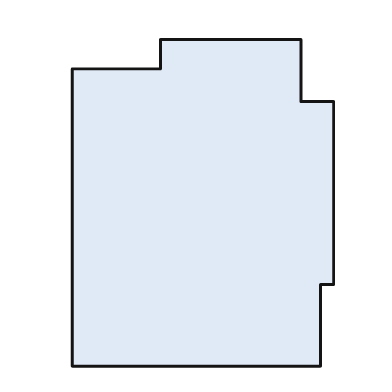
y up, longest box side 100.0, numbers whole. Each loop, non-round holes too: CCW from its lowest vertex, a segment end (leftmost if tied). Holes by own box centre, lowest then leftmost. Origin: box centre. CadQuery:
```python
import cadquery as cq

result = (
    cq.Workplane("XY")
    .moveTo(-40.0, -50.0)
    .lineTo(36.0, -50.0)
    .lineTo(36.0, -25.0)
    .lineTo(40.0, -25.0)
    .lineTo(40.0, 31.0)
    .lineTo(30.0, 31.0)
    .lineTo(30.0, 50.0)
    .lineTo(-13.0, 50.0)
    .lineTo(-13.0, 41.0)
    .lineTo(-40.0, 41.0)
    .close()
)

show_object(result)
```